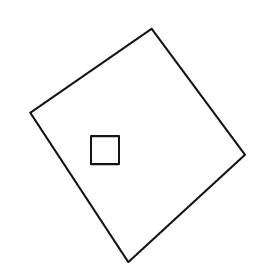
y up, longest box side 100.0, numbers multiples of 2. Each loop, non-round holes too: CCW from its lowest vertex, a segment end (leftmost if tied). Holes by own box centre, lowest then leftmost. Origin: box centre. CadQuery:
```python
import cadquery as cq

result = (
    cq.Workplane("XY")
    .moveTo(-4.0, -50.0)
    .lineTo(46.0, -4.0)
    .lineTo(6.0, 50.0)
    .lineTo(-46.0, 14.0)
    .close()
    .moveTo(-20.0, -8.0)
    .lineTo(-8.0, -8.0)
    .lineTo(-8.0, 4.0)
    .lineTo(-20.0, 4.0)
    .close()
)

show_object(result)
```